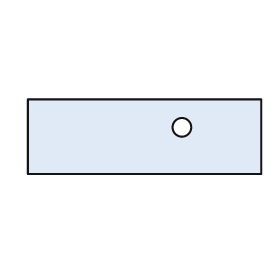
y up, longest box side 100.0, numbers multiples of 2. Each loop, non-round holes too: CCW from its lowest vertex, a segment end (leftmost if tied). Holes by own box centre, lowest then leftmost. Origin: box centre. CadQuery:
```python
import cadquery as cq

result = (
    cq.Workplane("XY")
    .moveTo(-50.0, -16.0)
    .lineTo(50.0, -16.0)
    .lineTo(50.0, 16.0)
    .lineTo(-50.0, 16.0)
    .close()
    .moveTo(16.0, 4.0)
    .circle(4.0)
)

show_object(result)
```